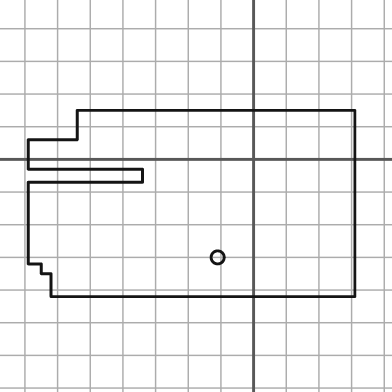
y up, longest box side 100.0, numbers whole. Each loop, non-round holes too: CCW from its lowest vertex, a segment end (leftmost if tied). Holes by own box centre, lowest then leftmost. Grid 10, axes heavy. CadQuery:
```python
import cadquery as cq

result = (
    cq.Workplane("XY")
    .moveTo(-62.0, -42.0)
    .lineTo(31.0, -42.0)
    .lineTo(31.0, 15.0)
    .lineTo(-54.0, 15.0)
    .lineTo(-54.0, 6.0)
    .lineTo(-69.0, 6.0)
    .lineTo(-69.0, -3.0)
    .lineTo(-34.0, -3.0)
    .lineTo(-34.0, -7.0)
    .lineTo(-69.0, -7.0)
    .lineTo(-69.0, -32.0)
    .lineTo(-65.0, -32.0)
    .lineTo(-65.0, -35.0)
    .lineTo(-62.0, -35.0)
    .close()
    .moveTo(-11.0, -30.0)
    .circle(2.0)
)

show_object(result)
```